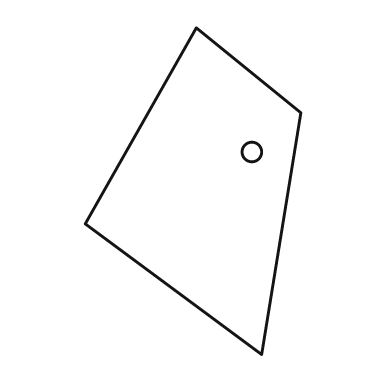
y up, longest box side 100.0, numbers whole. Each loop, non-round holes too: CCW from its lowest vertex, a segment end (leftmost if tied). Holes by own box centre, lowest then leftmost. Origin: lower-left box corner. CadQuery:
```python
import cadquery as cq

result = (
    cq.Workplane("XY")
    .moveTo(54.0, 0.0)
    .lineTo(66.0, 74.0)
    .lineTo(34.0, 100.0)
    .lineTo(0.0, 40.0)
    .close()
    .moveTo(51.0, 62.0)
    .circle(3.0)
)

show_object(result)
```